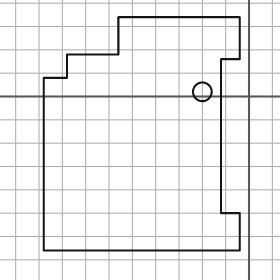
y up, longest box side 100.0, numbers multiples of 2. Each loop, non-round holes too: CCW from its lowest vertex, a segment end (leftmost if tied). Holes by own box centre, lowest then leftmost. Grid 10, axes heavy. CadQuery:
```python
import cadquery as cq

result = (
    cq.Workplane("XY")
    .moveTo(-88.0, -66.0)
    .lineTo(-4.0, -66.0)
    .lineTo(-4.0, -50.0)
    .lineTo(-12.0, -50.0)
    .lineTo(-12.0, 16.0)
    .lineTo(-4.0, 16.0)
    .lineTo(-4.0, 34.0)
    .lineTo(-56.0, 34.0)
    .lineTo(-56.0, 18.0)
    .lineTo(-78.0, 18.0)
    .lineTo(-78.0, 8.0)
    .lineTo(-88.0, 8.0)
    .close()
    .moveTo(-20.0, 2.0)
    .circle(4.0)
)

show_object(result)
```